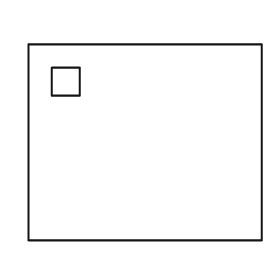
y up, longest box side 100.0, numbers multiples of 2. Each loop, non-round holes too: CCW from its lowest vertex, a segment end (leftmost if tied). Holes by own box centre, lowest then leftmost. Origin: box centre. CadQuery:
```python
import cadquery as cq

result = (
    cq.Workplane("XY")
    .moveTo(-50.0, -42.0)
    .lineTo(50.0, -42.0)
    .lineTo(50.0, 42.0)
    .lineTo(-50.0, 42.0)
    .close()
    .moveTo(-40.0, 20.0)
    .lineTo(-28.0, 20.0)
    .lineTo(-28.0, 32.0)
    .lineTo(-40.0, 32.0)
    .close()
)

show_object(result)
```